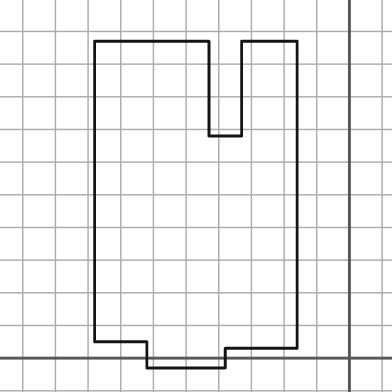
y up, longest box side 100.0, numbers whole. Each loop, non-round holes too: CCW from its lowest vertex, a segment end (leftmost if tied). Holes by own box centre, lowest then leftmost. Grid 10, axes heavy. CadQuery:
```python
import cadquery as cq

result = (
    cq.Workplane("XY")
    .moveTo(-62.0, -3.0)
    .lineTo(-38.0, -3.0)
    .lineTo(-38.0, 3.0)
    .lineTo(-16.0, 3.0)
    .lineTo(-16.0, 97.0)
    .lineTo(-33.0, 97.0)
    .lineTo(-33.0, 68.0)
    .lineTo(-43.0, 68.0)
    .lineTo(-43.0, 97.0)
    .lineTo(-78.0, 97.0)
    .lineTo(-78.0, 5.0)
    .lineTo(-62.0, 5.0)
    .close()
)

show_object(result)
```